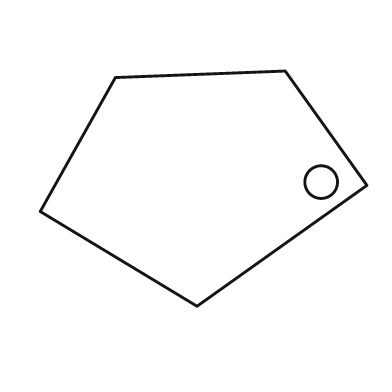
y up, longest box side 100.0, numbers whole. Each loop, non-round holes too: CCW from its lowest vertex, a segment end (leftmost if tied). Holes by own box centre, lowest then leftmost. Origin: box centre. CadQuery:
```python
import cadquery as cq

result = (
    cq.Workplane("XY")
    .moveTo(-2.0, -36.0)
    .lineTo(50.0, 1.0)
    .lineTo(25.0, 36.0)
    .lineTo(-27.0, 34.0)
    .lineTo(-50.0, -7.0)
    .close()
    .moveTo(36.0, 2.0)
    .circle(5.0)
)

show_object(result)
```